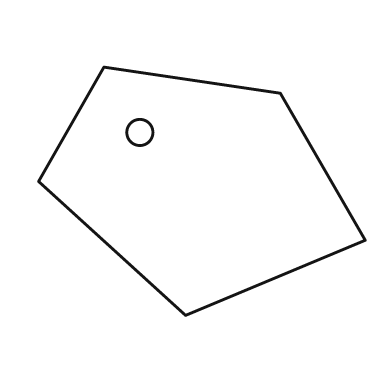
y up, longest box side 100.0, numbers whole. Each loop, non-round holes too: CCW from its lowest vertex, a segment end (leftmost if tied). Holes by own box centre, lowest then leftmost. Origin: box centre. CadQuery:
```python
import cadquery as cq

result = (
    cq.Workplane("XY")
    .moveTo(-5.0, -38.0)
    .lineTo(50.0, -15.0)
    .lineTo(24.0, 30.0)
    .lineTo(-30.0, 38.0)
    .lineTo(-50.0, 3.0)
    .close()
    .moveTo(-19.0, 18.0)
    .circle(4.0)
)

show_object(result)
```